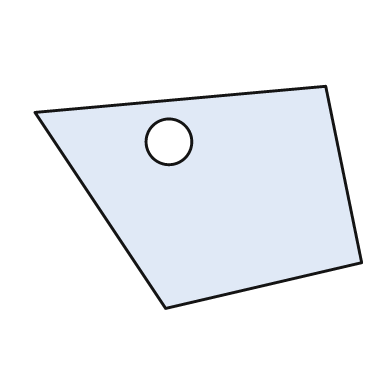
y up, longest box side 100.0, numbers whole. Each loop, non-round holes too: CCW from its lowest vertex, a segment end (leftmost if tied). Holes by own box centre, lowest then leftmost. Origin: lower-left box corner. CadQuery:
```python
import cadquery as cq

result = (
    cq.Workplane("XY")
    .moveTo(40.0, 0.0)
    .lineTo(100.0, 14.0)
    .lineTo(89.0, 68.0)
    .lineTo(0.0, 60.0)
    .close()
    .moveTo(41.0, 51.0)
    .circle(7.0)
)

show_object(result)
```